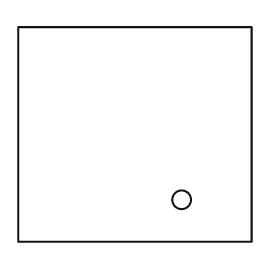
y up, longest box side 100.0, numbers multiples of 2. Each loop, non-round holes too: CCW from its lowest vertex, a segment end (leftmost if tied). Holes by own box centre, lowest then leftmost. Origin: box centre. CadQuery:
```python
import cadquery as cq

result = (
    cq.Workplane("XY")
    .moveTo(-50.0, -46.0)
    .lineTo(50.0, -46.0)
    .lineTo(50.0, 46.0)
    .lineTo(-50.0, 46.0)
    .close()
    .moveTo(20.0, -28.0)
    .circle(4.0)
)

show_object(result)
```